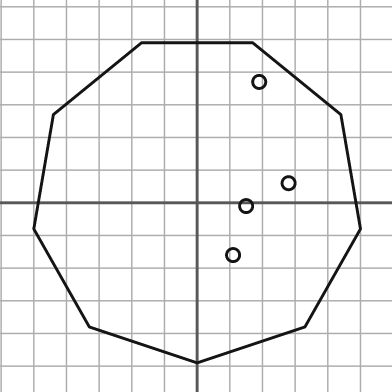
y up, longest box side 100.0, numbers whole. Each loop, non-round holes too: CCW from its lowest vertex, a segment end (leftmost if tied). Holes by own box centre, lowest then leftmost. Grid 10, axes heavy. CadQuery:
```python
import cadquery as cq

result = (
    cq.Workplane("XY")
    .moveTo(0.0, -49.0)
    .lineTo(33.0, -38.0)
    .lineTo(50.0, -8.0)
    .lineTo(44.0, 27.0)
    .lineTo(17.0, 49.0)
    .lineTo(-17.0, 49.0)
    .lineTo(-44.0, 27.0)
    .lineTo(-50.0, -8.0)
    .lineTo(-33.0, -38.0)
    .close()
    .moveTo(11.0, -16.0)
    .circle(2.0)
    .moveTo(15.0, -1.0)
    .circle(2.0)
    .moveTo(28.0, 6.0)
    .circle(2.0)
    .moveTo(19.0, 37.0)
    .circle(2.0)
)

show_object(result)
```